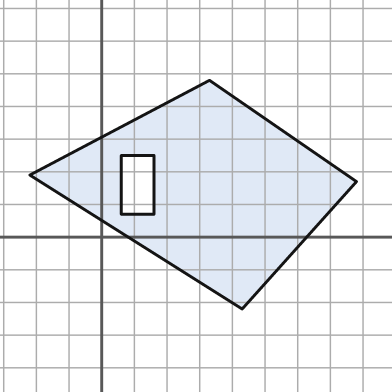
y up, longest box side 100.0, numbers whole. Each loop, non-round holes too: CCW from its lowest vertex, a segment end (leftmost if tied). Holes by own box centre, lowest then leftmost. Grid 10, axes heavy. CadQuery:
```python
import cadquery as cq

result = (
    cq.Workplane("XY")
    .moveTo(43.0, -22.0)
    .lineTo(78.0, 17.0)
    .lineTo(33.0, 48.0)
    .lineTo(-22.0, 19.0)
    .close()
    .moveTo(6.0, 7.0)
    .lineTo(16.0, 7.0)
    .lineTo(16.0, 25.0)
    .lineTo(6.0, 25.0)
    .close()
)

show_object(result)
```